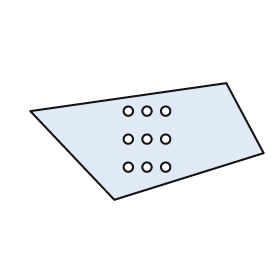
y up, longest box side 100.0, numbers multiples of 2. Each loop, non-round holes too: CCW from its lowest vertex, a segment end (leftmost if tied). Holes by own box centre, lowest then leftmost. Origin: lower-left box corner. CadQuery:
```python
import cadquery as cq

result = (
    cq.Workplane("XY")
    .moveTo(36.0, 0.0)
    .lineTo(100.0, 20.0)
    .lineTo(84.0, 50.0)
    .lineTo(0.0, 38.0)
    .close()
    .moveTo(42.0, 14.0)
    .circle(2.0)
    .moveTo(50.0, 14.0)
    .circle(2.0)
    .moveTo(58.0, 14.0)
    .circle(2.0)
    .moveTo(42.0, 26.0)
    .circle(2.0)
    .moveTo(50.0, 26.0)
    .circle(2.0)
    .moveTo(58.0, 26.0)
    .circle(2.0)
    .moveTo(42.0, 38.0)
    .circle(2.0)
    .moveTo(50.0, 38.0)
    .circle(2.0)
    .moveTo(58.0, 38.0)
    .circle(2.0)
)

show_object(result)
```